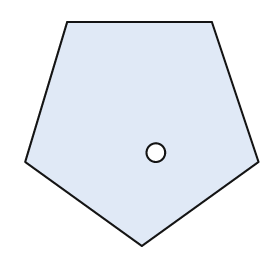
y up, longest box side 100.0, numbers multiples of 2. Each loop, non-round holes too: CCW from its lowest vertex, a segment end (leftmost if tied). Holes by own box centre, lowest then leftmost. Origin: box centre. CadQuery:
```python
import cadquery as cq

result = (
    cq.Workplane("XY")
    .moveTo(0.0, -48.0)
    .lineTo(50.0, -12.0)
    .lineTo(30.0, 48.0)
    .lineTo(-32.0, 48.0)
    .lineTo(-50.0, -12.0)
    .close()
    .moveTo(6.0, -8.0)
    .circle(4.0)
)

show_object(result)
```